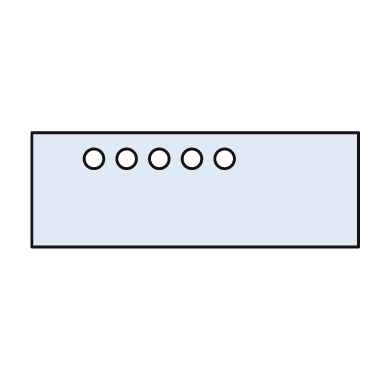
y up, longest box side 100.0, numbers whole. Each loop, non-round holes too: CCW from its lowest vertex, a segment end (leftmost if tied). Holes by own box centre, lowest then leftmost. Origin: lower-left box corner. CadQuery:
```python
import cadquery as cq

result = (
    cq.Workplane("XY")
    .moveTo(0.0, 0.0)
    .lineTo(100.0, 0.0)
    .lineTo(100.0, 35.0)
    .lineTo(0.0, 35.0)
    .close()
    .moveTo(19.0, 27.0)
    .circle(3.0)
    .moveTo(29.0, 27.0)
    .circle(3.0)
    .moveTo(39.0, 27.0)
    .circle(3.0)
    .moveTo(49.0, 27.0)
    .circle(3.0)
    .moveTo(59.0, 27.0)
    .circle(3.0)
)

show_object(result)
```